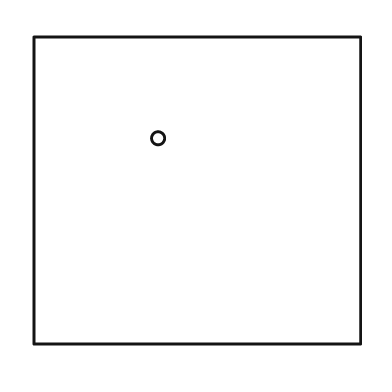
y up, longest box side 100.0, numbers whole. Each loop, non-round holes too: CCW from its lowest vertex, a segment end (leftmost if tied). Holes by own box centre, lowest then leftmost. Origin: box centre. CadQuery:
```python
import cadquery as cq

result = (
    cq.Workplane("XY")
    .moveTo(-50.0, -47.0)
    .lineTo(50.0, -47.0)
    .lineTo(50.0, 47.0)
    .lineTo(-50.0, 47.0)
    .close()
    .moveTo(-12.0, 16.0)
    .circle(2.0)
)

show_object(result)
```